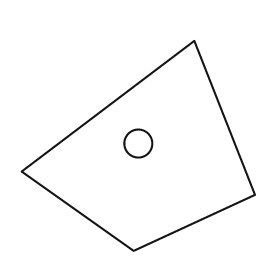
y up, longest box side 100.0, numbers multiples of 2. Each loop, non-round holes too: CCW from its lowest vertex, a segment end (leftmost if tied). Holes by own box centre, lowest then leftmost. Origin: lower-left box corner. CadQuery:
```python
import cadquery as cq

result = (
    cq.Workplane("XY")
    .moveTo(48.0, 0.0)
    .lineTo(100.0, 24.0)
    .lineTo(74.0, 90.0)
    .lineTo(0.0, 34.0)
    .close()
    .moveTo(50.0, 46.0)
    .circle(6.0)
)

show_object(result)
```